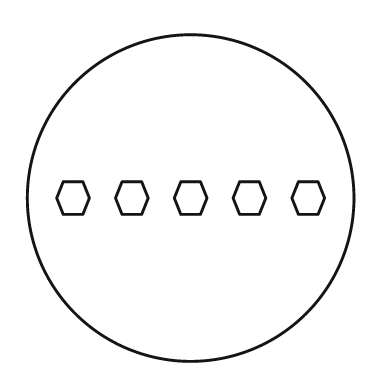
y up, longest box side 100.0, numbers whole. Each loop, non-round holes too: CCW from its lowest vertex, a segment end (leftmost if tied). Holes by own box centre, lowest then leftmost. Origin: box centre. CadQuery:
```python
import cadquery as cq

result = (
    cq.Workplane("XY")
    .moveTo(0.0, 0.0)
    .circle(50.0)
    .moveTo(-39.0, -5.0)
    .lineTo(-33.0, -5.0)
    .lineTo(-31.0, 0.0)
    .lineTo(-33.0, 5.0)
    .lineTo(-39.0, 5.0)
    .lineTo(-41.0, 0.0)
    .close()
    .moveTo(-21.0, -5.0)
    .lineTo(-15.0, -5.0)
    .lineTo(-13.0, 0.0)
    .lineTo(-15.0, 5.0)
    .lineTo(-21.0, 5.0)
    .lineTo(-23.0, 0.0)
    .close()
    .moveTo(-3.0, -5.0)
    .lineTo(3.0, -5.0)
    .lineTo(5.0, 0.0)
    .lineTo(3.0, 5.0)
    .lineTo(-3.0, 5.0)
    .lineTo(-5.0, 0.0)
    .close()
    .moveTo(15.0, -5.0)
    .lineTo(21.0, -5.0)
    .lineTo(23.0, 0.0)
    .lineTo(21.0, 5.0)
    .lineTo(15.0, 5.0)
    .lineTo(13.0, 0.0)
    .close()
    .moveTo(33.0, -5.0)
    .lineTo(39.0, -5.0)
    .lineTo(41.0, 0.0)
    .lineTo(39.0, 5.0)
    .lineTo(33.0, 5.0)
    .lineTo(31.0, 0.0)
    .close()
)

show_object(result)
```